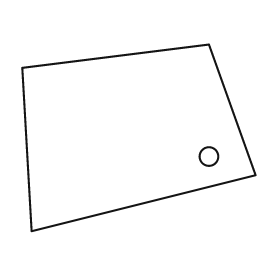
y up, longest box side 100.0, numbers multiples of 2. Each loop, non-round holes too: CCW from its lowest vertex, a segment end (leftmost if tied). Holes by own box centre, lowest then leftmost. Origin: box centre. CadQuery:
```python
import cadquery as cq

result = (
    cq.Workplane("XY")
    .moveTo(-46.0, -40.0)
    .lineTo(50.0, -16.0)
    .lineTo(30.0, 40.0)
    .lineTo(-50.0, 30.0)
    .close()
    .moveTo(30.0, -8.0)
    .circle(4.0)
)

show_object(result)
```